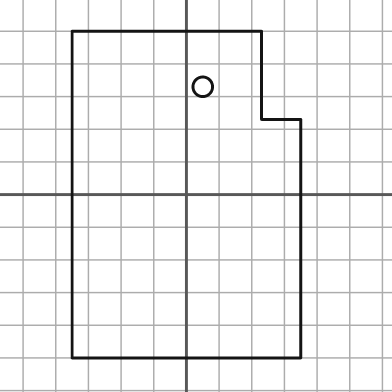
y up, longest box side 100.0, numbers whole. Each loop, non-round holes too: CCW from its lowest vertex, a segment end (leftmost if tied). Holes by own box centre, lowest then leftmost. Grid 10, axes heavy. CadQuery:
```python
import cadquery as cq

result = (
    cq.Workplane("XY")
    .moveTo(-35.0, -50.0)
    .lineTo(35.0, -50.0)
    .lineTo(35.0, 23.0)
    .lineTo(23.0, 23.0)
    .lineTo(23.0, 50.0)
    .lineTo(-35.0, 50.0)
    .close()
    .moveTo(5.0, 33.0)
    .circle(3.0)
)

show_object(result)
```